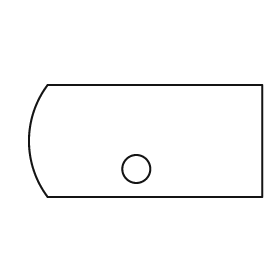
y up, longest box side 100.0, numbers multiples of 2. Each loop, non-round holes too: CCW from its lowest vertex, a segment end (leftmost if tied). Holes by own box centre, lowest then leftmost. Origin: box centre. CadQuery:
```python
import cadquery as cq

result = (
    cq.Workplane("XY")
    .moveTo(-42.0, -24.0)
    .lineTo(50.0, -24.0)
    .lineTo(50.0, 24.0)
    .lineTo(-42.0, 24.0)
    .threePointArc((-50.0, 0.0), (-42.0, -24.0))
    .close()
    .moveTo(-4.0, -12.0)
    .circle(6.0)
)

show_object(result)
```